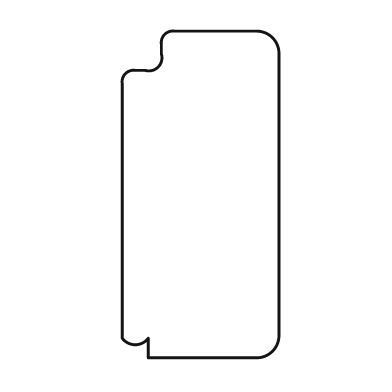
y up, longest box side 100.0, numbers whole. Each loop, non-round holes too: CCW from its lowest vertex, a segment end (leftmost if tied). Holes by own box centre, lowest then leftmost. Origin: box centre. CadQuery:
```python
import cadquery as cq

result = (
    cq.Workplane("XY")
    .moveTo(-16.0, -50.0)
    .lineTo(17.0, -50.0)
    .threePointArc((22.0, -48.0), (24.0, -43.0))
    .lineTo(24.0, 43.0)
    .threePointArc((22.0, 48.0), (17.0, 50.0))
    .lineTo(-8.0, 50.0)
    .threePointArc((-11.0, 49.0), (-12.0, 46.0))
    .lineTo(-12.0, 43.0)
    .threePointArc((-13.0, 39.0), (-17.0, 38.0))
    .lineTo(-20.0, 38.0)
    .threePointArc((-23.0, 37.0), (-24.0, 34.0))
    .lineTo(-24.0, -44.0)
    .threePointArc((-20.0, -46.0), (-16.0, -44.0))
    .close()
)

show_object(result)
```